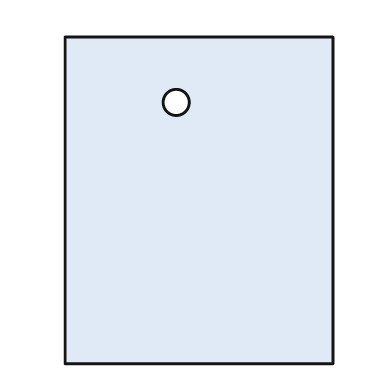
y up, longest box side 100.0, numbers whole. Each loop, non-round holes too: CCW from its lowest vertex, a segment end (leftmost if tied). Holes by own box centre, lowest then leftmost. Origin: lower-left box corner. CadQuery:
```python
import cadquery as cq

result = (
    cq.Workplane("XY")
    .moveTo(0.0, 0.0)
    .lineTo(82.0, 0.0)
    .lineTo(82.0, 100.0)
    .lineTo(0.0, 100.0)
    .close()
    .moveTo(34.0, 80.0)
    .circle(4.0)
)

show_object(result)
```